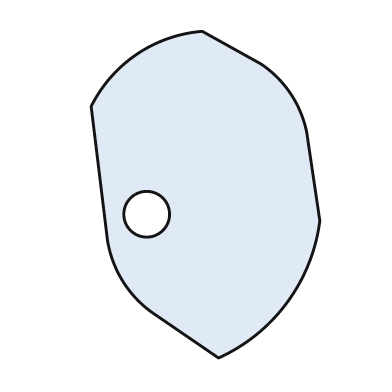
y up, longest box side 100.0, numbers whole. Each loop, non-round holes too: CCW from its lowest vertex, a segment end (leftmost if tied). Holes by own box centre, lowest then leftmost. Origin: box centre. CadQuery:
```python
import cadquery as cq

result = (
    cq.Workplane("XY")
    .moveTo(4.0, -50.0)
    .threePointArc((25.0, -33.0), (35.0, -8.0))
    .lineTo(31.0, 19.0)
    .threePointArc((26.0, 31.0), (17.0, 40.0))
    .lineTo(-1.0, 50.0)
    .threePointArc((-21.0, 43.0), (-35.0, 27.0))
    .lineTo(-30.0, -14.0)
    .threePointArc((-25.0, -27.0), (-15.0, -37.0))
    .close()
    .moveTo(-18.0, -6.0)
    .circle(7.0)
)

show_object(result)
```